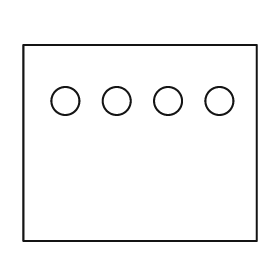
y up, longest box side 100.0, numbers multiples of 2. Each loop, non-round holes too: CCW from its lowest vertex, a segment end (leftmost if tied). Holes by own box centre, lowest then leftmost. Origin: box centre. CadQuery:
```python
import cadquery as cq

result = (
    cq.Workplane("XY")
    .moveTo(-50.0, -42.0)
    .lineTo(50.0, -42.0)
    .lineTo(50.0, 42.0)
    .lineTo(-50.0, 42.0)
    .close()
    .moveTo(-32.0, 18.0)
    .circle(6.0)
    .moveTo(-10.0, 18.0)
    .circle(6.0)
    .moveTo(12.0, 18.0)
    .circle(6.0)
    .moveTo(34.0, 18.0)
    .circle(6.0)
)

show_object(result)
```